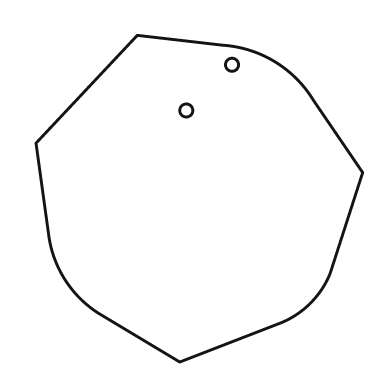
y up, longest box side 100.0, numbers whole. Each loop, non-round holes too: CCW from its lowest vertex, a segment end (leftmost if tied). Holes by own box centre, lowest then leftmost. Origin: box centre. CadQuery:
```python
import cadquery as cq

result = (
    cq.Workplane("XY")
    .moveTo(-6.0, -50.0)
    .lineTo(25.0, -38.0)
    .threePointArc((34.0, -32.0), (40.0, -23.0))
    .lineTo(50.0, 8.0)
    .lineTo(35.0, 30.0)
    .threePointArc((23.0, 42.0), (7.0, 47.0))
    .lineTo(-19.0, 50.0)
    .lineTo(-50.0, 17.0)
    .lineTo(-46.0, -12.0)
    .threePointArc((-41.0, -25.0), (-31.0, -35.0))
    .close()
    .moveTo(-4.0, 27.0)
    .circle(2.0)
    .moveTo(10.0, 41.0)
    .circle(2.0)
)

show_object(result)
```